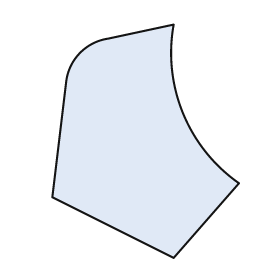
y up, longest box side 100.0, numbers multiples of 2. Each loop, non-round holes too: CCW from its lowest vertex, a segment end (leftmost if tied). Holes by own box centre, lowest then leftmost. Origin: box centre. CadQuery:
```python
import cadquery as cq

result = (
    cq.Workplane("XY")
    .moveTo(12.0, -50.0)
    .lineTo(40.0, -18.0)
    .threePointArc((16.0, 12.0), (12.0, 50.0))
    .lineTo(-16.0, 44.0)
    .threePointArc((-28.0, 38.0), (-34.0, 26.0))
    .lineTo(-40.0, -24.0)
    .close()
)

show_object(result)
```